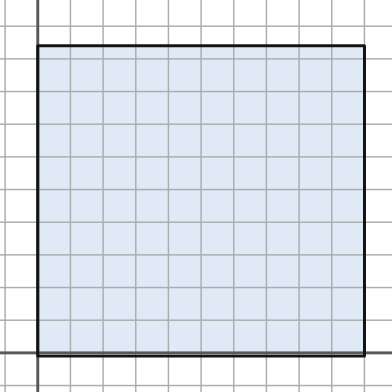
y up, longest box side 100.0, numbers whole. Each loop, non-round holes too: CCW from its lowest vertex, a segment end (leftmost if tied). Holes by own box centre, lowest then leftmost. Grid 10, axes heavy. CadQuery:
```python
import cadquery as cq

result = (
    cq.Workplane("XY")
    .moveTo(0.0, -1.0)
    .lineTo(100.0, -1.0)
    .lineTo(100.0, 94.0)
    .lineTo(0.0, 94.0)
    .close()
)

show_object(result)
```